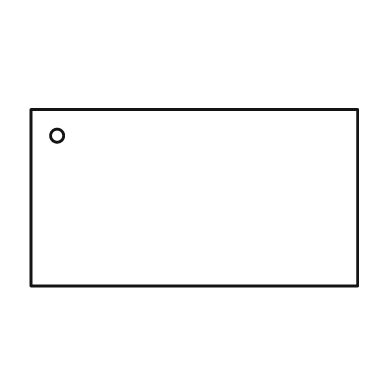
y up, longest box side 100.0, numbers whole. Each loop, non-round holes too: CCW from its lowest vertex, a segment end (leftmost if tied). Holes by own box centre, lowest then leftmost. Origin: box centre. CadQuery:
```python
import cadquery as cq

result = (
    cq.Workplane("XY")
    .moveTo(-50.0, -27.0)
    .lineTo(50.0, -27.0)
    .lineTo(50.0, 27.0)
    .lineTo(-50.0, 27.0)
    .close()
    .moveTo(-42.0, 19.0)
    .circle(2.0)
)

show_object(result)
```